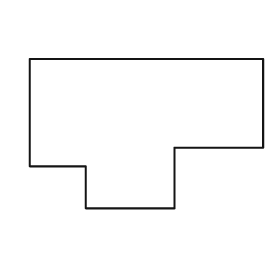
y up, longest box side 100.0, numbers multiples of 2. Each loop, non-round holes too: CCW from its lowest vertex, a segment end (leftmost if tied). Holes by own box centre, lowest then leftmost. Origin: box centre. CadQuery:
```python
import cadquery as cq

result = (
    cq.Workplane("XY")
    .moveTo(-26.0, -32.0)
    .lineTo(12.0, -32.0)
    .lineTo(12.0, -6.0)
    .lineTo(50.0, -6.0)
    .lineTo(50.0, 32.0)
    .lineTo(-50.0, 32.0)
    .lineTo(-50.0, -14.0)
    .lineTo(-26.0, -14.0)
    .close()
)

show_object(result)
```